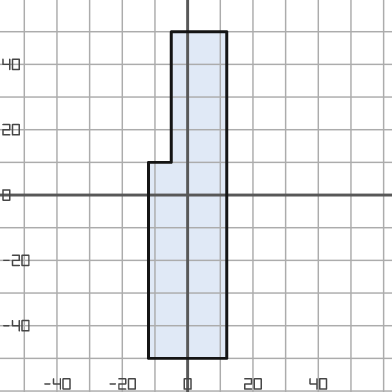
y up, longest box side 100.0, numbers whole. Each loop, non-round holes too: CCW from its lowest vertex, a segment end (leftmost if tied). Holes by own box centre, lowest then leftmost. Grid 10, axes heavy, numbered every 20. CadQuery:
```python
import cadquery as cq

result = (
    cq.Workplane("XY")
    .moveTo(-12.0, -50.0)
    .lineTo(12.0, -50.0)
    .lineTo(12.0, 50.0)
    .lineTo(-5.0, 50.0)
    .lineTo(-5.0, 10.0)
    .lineTo(-12.0, 10.0)
    .close()
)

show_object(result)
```